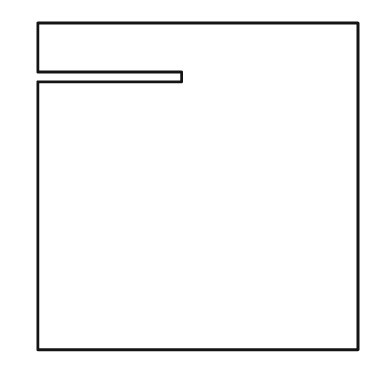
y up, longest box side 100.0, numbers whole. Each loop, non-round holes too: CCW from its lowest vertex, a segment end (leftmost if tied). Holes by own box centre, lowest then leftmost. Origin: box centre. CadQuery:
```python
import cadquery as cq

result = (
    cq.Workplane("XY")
    .moveTo(-49.0, -50.0)
    .lineTo(49.0, -50.0)
    .lineTo(49.0, 50.0)
    .lineTo(-49.0, 50.0)
    .lineTo(-49.0, 35.0)
    .lineTo(-5.0, 35.0)
    .lineTo(-5.0, 32.0)
    .lineTo(-49.0, 32.0)
    .close()
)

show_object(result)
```